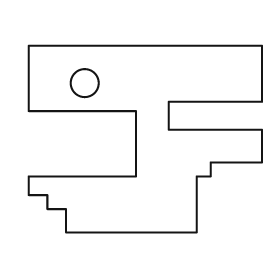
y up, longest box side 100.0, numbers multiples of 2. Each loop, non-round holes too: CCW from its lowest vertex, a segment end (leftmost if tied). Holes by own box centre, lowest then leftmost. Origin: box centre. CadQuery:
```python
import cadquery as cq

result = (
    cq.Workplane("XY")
    .moveTo(-34.0, -40.0)
    .lineTo(22.0, -40.0)
    .lineTo(22.0, -16.0)
    .lineTo(28.0, -16.0)
    .lineTo(28.0, -10.0)
    .lineTo(50.0, -10.0)
    .lineTo(50.0, 4.0)
    .lineTo(10.0, 4.0)
    .lineTo(10.0, 16.0)
    .lineTo(50.0, 16.0)
    .lineTo(50.0, 40.0)
    .lineTo(-50.0, 40.0)
    .lineTo(-50.0, 12.0)
    .lineTo(-4.0, 12.0)
    .lineTo(-4.0, -16.0)
    .lineTo(-50.0, -16.0)
    .lineTo(-50.0, -24.0)
    .lineTo(-42.0, -24.0)
    .lineTo(-42.0, -30.0)
    .lineTo(-34.0, -30.0)
    .close()
    .moveTo(-26.0, 24.0)
    .circle(6.0)
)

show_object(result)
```